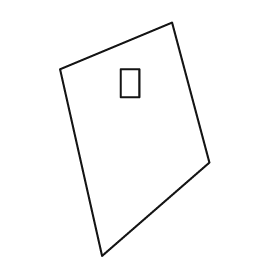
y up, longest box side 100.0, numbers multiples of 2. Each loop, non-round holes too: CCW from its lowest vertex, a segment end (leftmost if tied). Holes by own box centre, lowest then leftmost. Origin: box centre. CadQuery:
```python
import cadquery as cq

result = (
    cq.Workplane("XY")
    .moveTo(-14.0, -50.0)
    .lineTo(32.0, -10.0)
    .lineTo(16.0, 50.0)
    .lineTo(-32.0, 30.0)
    .close()
    .moveTo(-6.0, 18.0)
    .lineTo(2.0, 18.0)
    .lineTo(2.0, 30.0)
    .lineTo(-6.0, 30.0)
    .close()
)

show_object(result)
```